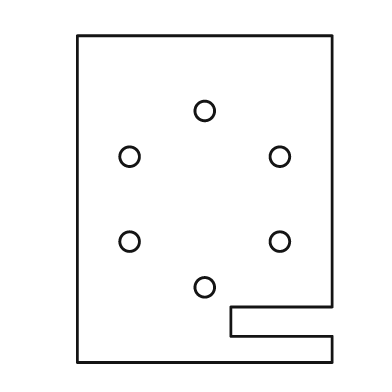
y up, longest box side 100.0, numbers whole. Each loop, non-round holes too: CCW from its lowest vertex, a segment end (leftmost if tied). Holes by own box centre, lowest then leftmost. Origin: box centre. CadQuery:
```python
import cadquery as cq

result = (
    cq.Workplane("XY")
    .moveTo(-39.0, -50.0)
    .lineTo(39.0, -50.0)
    .lineTo(39.0, -42.0)
    .lineTo(8.0, -42.0)
    .lineTo(8.0, -33.0)
    .lineTo(39.0, -33.0)
    .lineTo(39.0, 50.0)
    .lineTo(-39.0, 50.0)
    .close()
    .moveTo(0.0, -27.0)
    .circle(3.0)
    .moveTo(-23.0, -13.0)
    .circle(3.0)
    .moveTo(23.0, -13.0)
    .circle(3.0)
    .moveTo(-23.0, 13.0)
    .circle(3.0)
    .moveTo(23.0, 13.0)
    .circle(3.0)
    .moveTo(0.0, 27.0)
    .circle(3.0)
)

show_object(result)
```